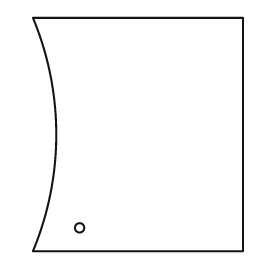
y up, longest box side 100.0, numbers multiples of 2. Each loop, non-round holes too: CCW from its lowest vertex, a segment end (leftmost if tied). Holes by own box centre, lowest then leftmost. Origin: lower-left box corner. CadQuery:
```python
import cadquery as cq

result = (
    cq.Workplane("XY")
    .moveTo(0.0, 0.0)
    .lineTo(90.0, 0.0)
    .lineTo(90.0, 100.0)
    .lineTo(0.0, 100.0)
    .threePointArc((10.0, 50.0), (0.0, 0.0))
    .close()
    .moveTo(20.0, 10.0)
    .circle(2.0)
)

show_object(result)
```